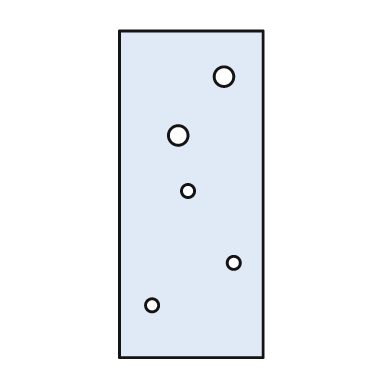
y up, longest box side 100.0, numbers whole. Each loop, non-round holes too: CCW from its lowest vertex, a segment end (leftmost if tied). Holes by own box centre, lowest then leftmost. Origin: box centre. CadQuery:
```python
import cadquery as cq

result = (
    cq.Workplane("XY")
    .moveTo(-22.0, -50.0)
    .lineTo(22.0, -50.0)
    .lineTo(22.0, 50.0)
    .lineTo(-22.0, 50.0)
    .close()
    .moveTo(-12.0, -34.0)
    .circle(2.0)
    .moveTo(13.0, -21.0)
    .circle(2.0)
    .moveTo(-1.0, 1.0)
    .circle(2.0)
    .moveTo(-4.0, 18.0)
    .circle(3.0)
    .moveTo(10.0, 36.0)
    .circle(3.0)
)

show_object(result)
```